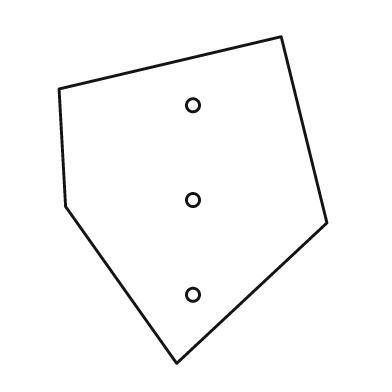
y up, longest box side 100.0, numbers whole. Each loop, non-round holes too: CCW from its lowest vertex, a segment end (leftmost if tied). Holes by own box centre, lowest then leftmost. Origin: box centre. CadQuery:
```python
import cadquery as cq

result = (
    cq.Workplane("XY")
    .moveTo(-5.0, -50.0)
    .lineTo(41.0, -7.0)
    .lineTo(27.0, 50.0)
    .lineTo(-41.0, 34.0)
    .lineTo(-39.0, -2.0)
    .close()
    .moveTo(0.0, -29.0)
    .circle(2.0)
    .moveTo(0.0, 0.0)
    .circle(2.0)
    .moveTo(0.0, 29.0)
    .circle(2.0)
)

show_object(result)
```